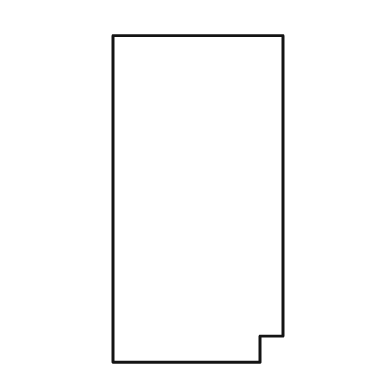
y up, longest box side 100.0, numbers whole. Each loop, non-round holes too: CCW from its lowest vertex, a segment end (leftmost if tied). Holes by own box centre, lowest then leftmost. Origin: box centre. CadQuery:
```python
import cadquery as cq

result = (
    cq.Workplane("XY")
    .moveTo(-26.0, -50.0)
    .lineTo(19.0, -50.0)
    .lineTo(19.0, -42.0)
    .lineTo(26.0, -42.0)
    .lineTo(26.0, 50.0)
    .lineTo(-26.0, 50.0)
    .close()
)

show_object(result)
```